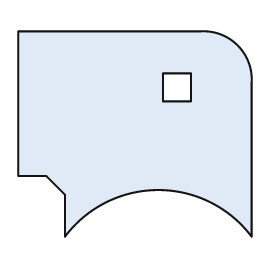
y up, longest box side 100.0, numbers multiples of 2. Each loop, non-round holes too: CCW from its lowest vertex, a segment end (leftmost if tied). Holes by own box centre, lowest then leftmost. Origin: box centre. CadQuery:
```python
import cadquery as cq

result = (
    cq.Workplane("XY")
    .moveTo(-30.0, -44.0)
    .threePointArc((10.0, -24.0), (50.0, -44.0))
    .lineTo(50.0, 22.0)
    .threePointArc((44.0, 38.0), (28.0, 44.0))
    .lineTo(-50.0, 44.0)
    .lineTo(-50.0, -18.0)
    .lineTo(-38.0, -18.0)
    .lineTo(-30.0, -26.0)
    .close()
    .moveTo(12.0, 14.0)
    .lineTo(24.0, 14.0)
    .lineTo(24.0, 26.0)
    .lineTo(12.0, 26.0)
    .close()
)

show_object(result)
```